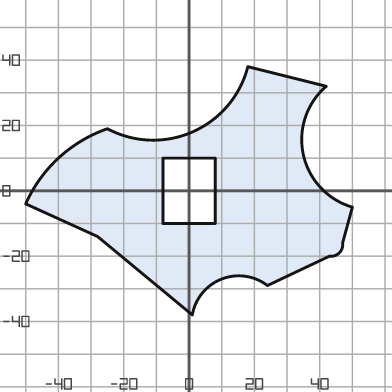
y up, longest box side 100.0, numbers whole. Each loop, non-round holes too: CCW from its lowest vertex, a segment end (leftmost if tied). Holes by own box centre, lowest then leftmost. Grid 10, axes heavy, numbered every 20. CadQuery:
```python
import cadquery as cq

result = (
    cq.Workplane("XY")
    .moveTo(1.0, -38.0)
    .threePointArc((10.0, -27.0), (24.0, -29.0))
    .lineTo(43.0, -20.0)
    .threePointArc((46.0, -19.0), (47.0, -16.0))
    .lineTo(50.0, -5.0)
    .threePointArc((35.0, 11.0), (42.0, 32.0))
    .lineTo(18.0, 38.0)
    .threePointArc((1.0, 18.0), (-25.0, 19.0))
    .threePointArc((-40.0, 10.0), (-50.0, -4.0))
    .lineTo(-28.0, -14.0)
    .close()
    .moveTo(-8.0, -10.0)
    .lineTo(8.0, -10.0)
    .lineTo(8.0, 10.0)
    .lineTo(-8.0, 10.0)
    .close()
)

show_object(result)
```